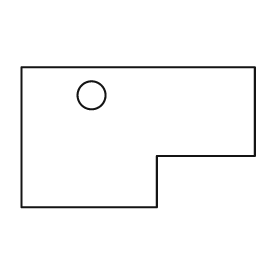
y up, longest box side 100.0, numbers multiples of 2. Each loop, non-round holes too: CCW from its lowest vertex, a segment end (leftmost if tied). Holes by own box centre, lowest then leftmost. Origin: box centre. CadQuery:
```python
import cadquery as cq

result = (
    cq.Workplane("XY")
    .moveTo(-50.0, -30.0)
    .lineTo(8.0, -30.0)
    .lineTo(8.0, -8.0)
    .lineTo(50.0, -8.0)
    .lineTo(50.0, 30.0)
    .lineTo(-50.0, 30.0)
    .close()
    .moveTo(-20.0, 18.0)
    .circle(6.0)
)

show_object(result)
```